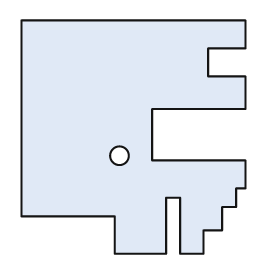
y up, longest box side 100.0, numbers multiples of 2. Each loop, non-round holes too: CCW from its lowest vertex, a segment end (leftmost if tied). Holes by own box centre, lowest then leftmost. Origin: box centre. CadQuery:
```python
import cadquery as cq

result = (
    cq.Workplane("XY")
    .moveTo(-8.0, -50.0)
    .lineTo(14.0, -50.0)
    .lineTo(14.0, -26.0)
    .lineTo(20.0, -26.0)
    .lineTo(20.0, -50.0)
    .lineTo(30.0, -50.0)
    .lineTo(30.0, -40.0)
    .lineTo(38.0, -40.0)
    .lineTo(38.0, -30.0)
    .lineTo(44.0, -30.0)
    .lineTo(44.0, -22.0)
    .lineTo(48.0, -22.0)
    .lineTo(48.0, -10.0)
    .lineTo(8.0, -10.0)
    .lineTo(8.0, 12.0)
    .lineTo(48.0, 12.0)
    .lineTo(48.0, 26.0)
    .lineTo(32.0, 26.0)
    .lineTo(32.0, 38.0)
    .lineTo(48.0, 38.0)
    .lineTo(48.0, 50.0)
    .lineTo(-48.0, 50.0)
    .lineTo(-48.0, -34.0)
    .lineTo(-8.0, -34.0)
    .close()
    .moveTo(-6.0, -8.0)
    .circle(4.0)
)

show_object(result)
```